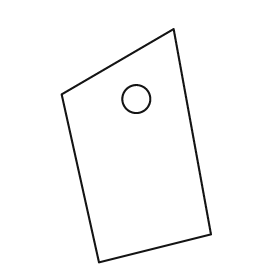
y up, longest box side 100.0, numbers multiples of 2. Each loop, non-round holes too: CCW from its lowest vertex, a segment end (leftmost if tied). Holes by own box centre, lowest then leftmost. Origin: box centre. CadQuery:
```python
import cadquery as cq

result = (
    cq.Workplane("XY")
    .moveTo(-16.0, -50.0)
    .lineTo(32.0, -38.0)
    .lineTo(16.0, 50.0)
    .lineTo(-32.0, 22.0)
    .close()
    .moveTo(0.0, 20.0)
    .circle(6.0)
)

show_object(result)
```